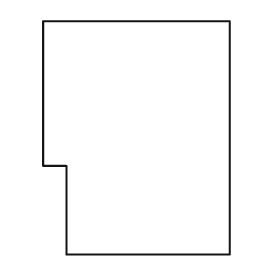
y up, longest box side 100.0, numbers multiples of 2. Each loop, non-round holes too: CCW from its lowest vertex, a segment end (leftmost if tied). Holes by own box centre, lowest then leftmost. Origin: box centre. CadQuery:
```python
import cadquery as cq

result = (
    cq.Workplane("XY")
    .moveTo(-30.0, -50.0)
    .lineTo(40.0, -50.0)
    .lineTo(40.0, 50.0)
    .lineTo(-40.0, 50.0)
    .lineTo(-40.0, -12.0)
    .lineTo(-30.0, -12.0)
    .close()
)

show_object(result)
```